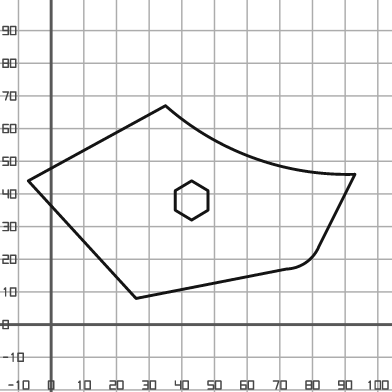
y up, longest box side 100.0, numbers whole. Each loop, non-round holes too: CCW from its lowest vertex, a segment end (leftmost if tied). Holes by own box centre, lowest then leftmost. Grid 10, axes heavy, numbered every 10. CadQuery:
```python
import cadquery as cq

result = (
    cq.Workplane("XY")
    .moveTo(26.0, 8.0)
    .lineTo(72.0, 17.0)
    .threePointArc((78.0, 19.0), (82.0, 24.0))
    .lineTo(93.0, 46.0)
    .threePointArc((62.0, 51.0), (35.0, 67.0))
    .lineTo(-7.0, 44.0)
    .close()
    .moveTo(43.0, 32.0)
    .lineTo(48.0, 35.0)
    .lineTo(48.0, 41.0)
    .lineTo(43.0, 44.0)
    .lineTo(38.0, 41.0)
    .lineTo(38.0, 35.0)
    .close()
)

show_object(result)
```